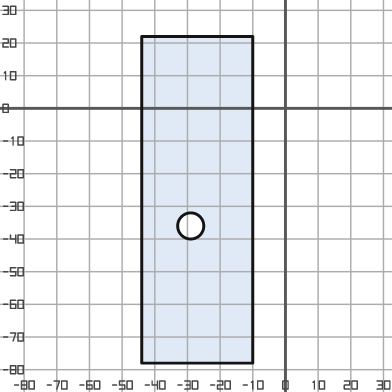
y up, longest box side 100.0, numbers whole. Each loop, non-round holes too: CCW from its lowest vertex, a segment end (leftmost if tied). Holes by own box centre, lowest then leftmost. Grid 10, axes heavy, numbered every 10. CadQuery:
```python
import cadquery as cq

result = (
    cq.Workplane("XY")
    .moveTo(-44.0, -78.0)
    .lineTo(-10.0, -78.0)
    .lineTo(-10.0, 22.0)
    .lineTo(-44.0, 22.0)
    .close()
    .moveTo(-29.0, -36.0)
    .circle(4.0)
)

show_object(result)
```